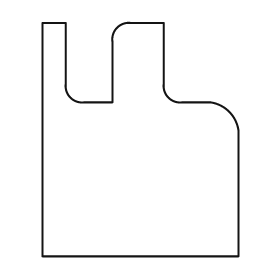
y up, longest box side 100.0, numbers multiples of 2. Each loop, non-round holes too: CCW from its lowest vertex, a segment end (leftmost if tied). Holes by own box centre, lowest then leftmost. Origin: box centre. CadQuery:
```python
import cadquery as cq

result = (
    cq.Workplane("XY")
    .moveTo(-42.0, -50.0)
    .lineTo(42.0, -50.0)
    .lineTo(42.0, 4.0)
    .threePointArc((38.0, 12.0), (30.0, 16.0))
    .lineTo(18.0, 16.0)
    .threePointArc((12.0, 18.0), (10.0, 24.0))
    .lineTo(10.0, 50.0)
    .lineTo(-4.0, 50.0)
    .threePointArc((-10.0, 48.0), (-12.0, 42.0))
    .lineTo(-12.0, 16.0)
    .lineTo(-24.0, 16.0)
    .threePointArc((-30.0, 18.0), (-32.0, 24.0))
    .lineTo(-32.0, 50.0)
    .lineTo(-42.0, 50.0)
    .close()
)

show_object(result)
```